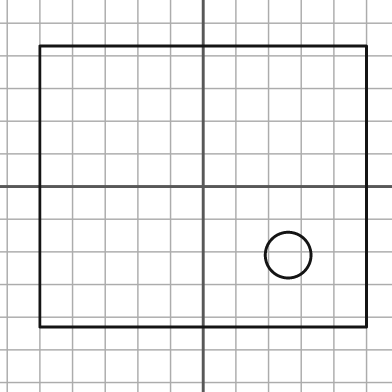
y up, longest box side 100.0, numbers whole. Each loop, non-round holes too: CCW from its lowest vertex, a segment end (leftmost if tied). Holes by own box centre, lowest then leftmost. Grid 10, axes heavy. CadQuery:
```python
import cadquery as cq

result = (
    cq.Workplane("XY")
    .moveTo(-50.0, -43.0)
    .lineTo(50.0, -43.0)
    .lineTo(50.0, 43.0)
    .lineTo(-50.0, 43.0)
    .close()
    .moveTo(26.0, -21.0)
    .circle(7.0)
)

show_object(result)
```